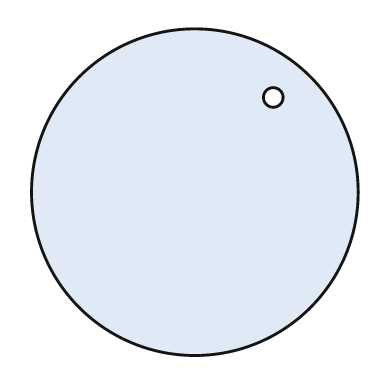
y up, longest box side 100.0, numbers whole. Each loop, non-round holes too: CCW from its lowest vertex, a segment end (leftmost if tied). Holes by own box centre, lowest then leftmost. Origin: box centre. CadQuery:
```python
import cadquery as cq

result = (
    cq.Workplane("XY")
    .moveTo(0.0, 0.0)
    .circle(50.0)
    .moveTo(24.0, 29.0)
    .circle(3.0)
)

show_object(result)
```